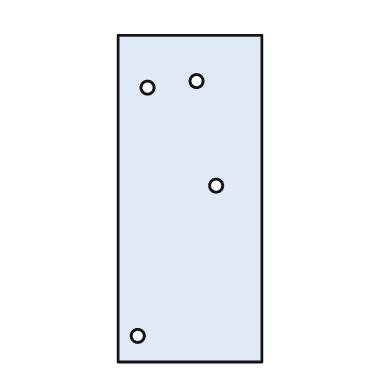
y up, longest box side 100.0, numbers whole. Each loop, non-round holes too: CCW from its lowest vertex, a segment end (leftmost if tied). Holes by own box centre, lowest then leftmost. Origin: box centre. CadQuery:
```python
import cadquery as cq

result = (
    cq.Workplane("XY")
    .moveTo(-22.0, -50.0)
    .lineTo(22.0, -50.0)
    .lineTo(22.0, 50.0)
    .lineTo(-22.0, 50.0)
    .close()
    .moveTo(-16.0, -42.0)
    .circle(2.0)
    .moveTo(8.0, 4.0)
    .circle(2.0)
    .moveTo(-13.0, 34.0)
    .circle(2.0)
    .moveTo(2.0, 36.0)
    .circle(2.0)
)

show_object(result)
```